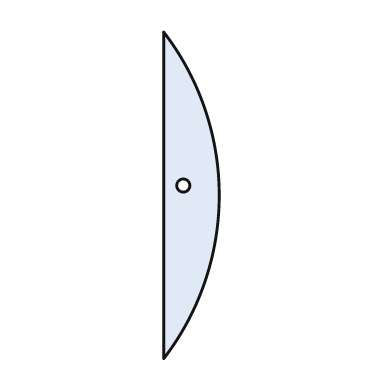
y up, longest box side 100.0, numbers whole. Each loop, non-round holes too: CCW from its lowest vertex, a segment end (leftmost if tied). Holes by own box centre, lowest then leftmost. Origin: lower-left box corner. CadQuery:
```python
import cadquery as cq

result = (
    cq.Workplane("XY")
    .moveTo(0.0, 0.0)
    .threePointArc((17.0, 50.0), (0.0, 100.0))
    .close()
    .moveTo(6.0, 53.0)
    .circle(2.0)
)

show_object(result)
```